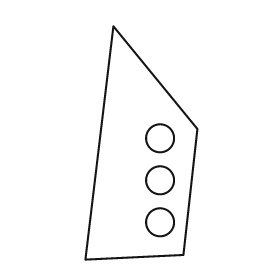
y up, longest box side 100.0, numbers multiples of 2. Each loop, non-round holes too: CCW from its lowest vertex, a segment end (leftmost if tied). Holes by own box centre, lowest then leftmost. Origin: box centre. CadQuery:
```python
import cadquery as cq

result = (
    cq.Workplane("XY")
    .moveTo(-24.0, -50.0)
    .lineTo(18.0, -48.0)
    .lineTo(24.0, 6.0)
    .lineTo(-12.0, 50.0)
    .close()
    .moveTo(8.0, -34.0)
    .circle(6.0)
    .moveTo(8.0, -16.0)
    .circle(6.0)
    .moveTo(8.0, 2.0)
    .circle(6.0)
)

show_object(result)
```